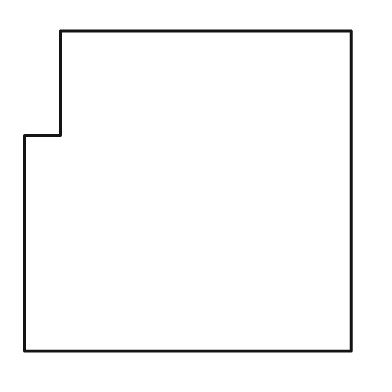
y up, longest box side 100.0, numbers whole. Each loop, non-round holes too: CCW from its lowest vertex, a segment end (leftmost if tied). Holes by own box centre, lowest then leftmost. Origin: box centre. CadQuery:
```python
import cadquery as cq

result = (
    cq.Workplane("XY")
    .moveTo(-50.0, -49.0)
    .lineTo(50.0, -49.0)
    .lineTo(50.0, 49.0)
    .lineTo(-39.0, 49.0)
    .lineTo(-39.0, 17.0)
    .lineTo(-50.0, 17.0)
    .close()
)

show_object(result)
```